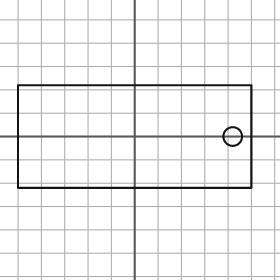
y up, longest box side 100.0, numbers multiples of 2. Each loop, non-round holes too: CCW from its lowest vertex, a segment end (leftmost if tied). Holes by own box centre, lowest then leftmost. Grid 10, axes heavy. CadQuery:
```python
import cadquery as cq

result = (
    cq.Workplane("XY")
    .moveTo(-50.0, -22.0)
    .lineTo(50.0, -22.0)
    .lineTo(50.0, 22.0)
    .lineTo(-50.0, 22.0)
    .close()
    .moveTo(42.0, 0.0)
    .circle(4.0)
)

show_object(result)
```